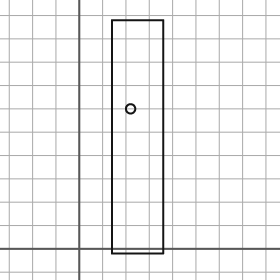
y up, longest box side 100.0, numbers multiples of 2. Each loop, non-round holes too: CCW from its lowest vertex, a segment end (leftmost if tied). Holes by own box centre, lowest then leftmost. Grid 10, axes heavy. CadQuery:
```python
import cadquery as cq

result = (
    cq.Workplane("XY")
    .moveTo(14.0, -2.0)
    .lineTo(36.0, -2.0)
    .lineTo(36.0, 98.0)
    .lineTo(14.0, 98.0)
    .close()
    .moveTo(22.0, 60.0)
    .circle(2.0)
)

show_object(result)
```